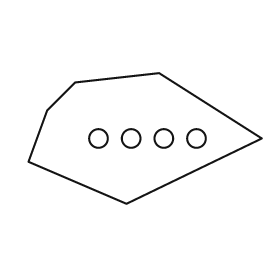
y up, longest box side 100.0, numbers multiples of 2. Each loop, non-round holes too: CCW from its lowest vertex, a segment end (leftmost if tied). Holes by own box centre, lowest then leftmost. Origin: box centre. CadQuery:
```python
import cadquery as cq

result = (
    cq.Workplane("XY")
    .moveTo(-8.0, -28.0)
    .lineTo(50.0, 0.0)
    .lineTo(6.0, 28.0)
    .lineTo(-30.0, 24.0)
    .lineTo(-42.0, 12.0)
    .lineTo(-50.0, -10.0)
    .close()
    .moveTo(-20.0, 0.0)
    .circle(4.0)
    .moveTo(-6.0, 0.0)
    .circle(4.0)
    .moveTo(8.0, 0.0)
    .circle(4.0)
    .moveTo(22.0, 0.0)
    .circle(4.0)
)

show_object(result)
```